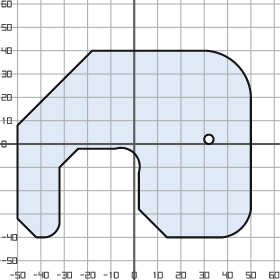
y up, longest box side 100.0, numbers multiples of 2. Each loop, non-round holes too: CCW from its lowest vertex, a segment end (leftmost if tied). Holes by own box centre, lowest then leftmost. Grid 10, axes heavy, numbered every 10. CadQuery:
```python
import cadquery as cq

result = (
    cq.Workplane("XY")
    .moveTo(-42.0, -40.0)
    .lineTo(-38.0, -40.0)
    .threePointArc((-34.0, -38.0), (-32.0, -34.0))
    .lineTo(-32.0, -10.0)
    .lineTo(-24.0, -2.0)
    .lineTo(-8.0, -2.0)
    .threePointArc((0.0, -4.0), (2.0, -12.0))
    .lineTo(2.0, -28.0)
    .lineTo(14.0, -40.0)
    .lineTo(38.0, -40.0)
    .threePointArc((46.0, -36.0), (50.0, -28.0))
    .lineTo(50.0, 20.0)
    .threePointArc((44.0, 34.0), (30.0, 40.0))
    .lineTo(-18.0, 40.0)
    .lineTo(-50.0, 8.0)
    .lineTo(-50.0, -32.0)
    .close()
    .moveTo(32.0, 2.0)
    .circle(2.0)
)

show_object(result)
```